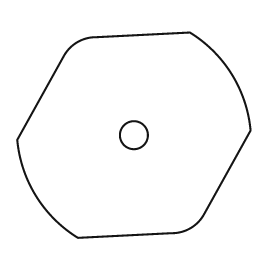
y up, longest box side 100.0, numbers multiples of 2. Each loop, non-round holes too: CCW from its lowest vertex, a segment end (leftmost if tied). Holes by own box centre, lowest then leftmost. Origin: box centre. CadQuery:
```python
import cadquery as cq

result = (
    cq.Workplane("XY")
    .moveTo(-24.0, -44.0)
    .lineTo(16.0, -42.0)
    .threePointArc((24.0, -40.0), (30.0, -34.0))
    .lineTo(50.0, 2.0)
    .threePointArc((42.0, 26.0), (24.0, 44.0))
    .lineTo(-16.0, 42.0)
    .threePointArc((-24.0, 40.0), (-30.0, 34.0))
    .lineTo(-50.0, -2.0)
    .threePointArc((-42.0, -26.0), (-24.0, -44.0))
    .close()
    .moveTo(0.0, 0.0)
    .circle(6.0)
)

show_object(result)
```